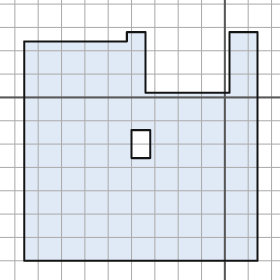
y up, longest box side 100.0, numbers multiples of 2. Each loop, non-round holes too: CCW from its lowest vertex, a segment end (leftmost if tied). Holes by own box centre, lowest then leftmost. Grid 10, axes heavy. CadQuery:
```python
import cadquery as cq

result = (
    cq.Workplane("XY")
    .moveTo(-86.0, -70.0)
    .lineTo(14.0, -70.0)
    .lineTo(14.0, 28.0)
    .lineTo(2.0, 28.0)
    .lineTo(2.0, 2.0)
    .lineTo(-34.0, 2.0)
    .lineTo(-34.0, 28.0)
    .lineTo(-42.0, 28.0)
    .lineTo(-42.0, 24.0)
    .lineTo(-86.0, 24.0)
    .close()
    .moveTo(-40.0, -26.0)
    .lineTo(-32.0, -26.0)
    .lineTo(-32.0, -14.0)
    .lineTo(-40.0, -14.0)
    .close()
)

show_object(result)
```